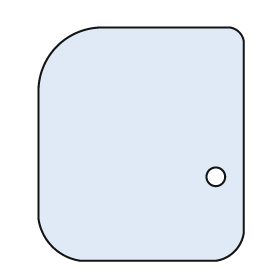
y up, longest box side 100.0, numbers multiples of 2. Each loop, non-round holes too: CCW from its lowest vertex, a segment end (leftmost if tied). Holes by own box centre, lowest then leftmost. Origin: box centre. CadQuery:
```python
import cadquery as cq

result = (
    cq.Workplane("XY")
    .moveTo(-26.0, -50.0)
    .lineTo(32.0, -50.0)
    .threePointArc((40.0, -46.0), (44.0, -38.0))
    .lineTo(44.0, 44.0)
    .threePointArc((42.0, 48.0), (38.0, 50.0))
    .lineTo(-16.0, 50.0)
    .threePointArc((-36.0, 42.0), (-44.0, 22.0))
    .lineTo(-44.0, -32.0)
    .threePointArc((-38.0, -44.0), (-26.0, -50.0))
    .close()
    .moveTo(32.0, -14.0)
    .circle(4.0)
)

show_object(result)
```